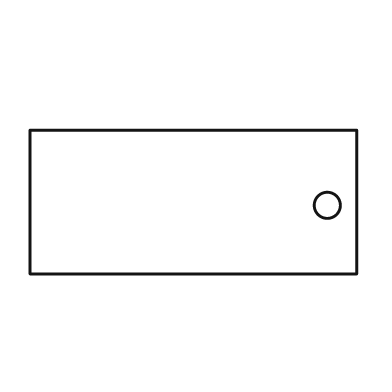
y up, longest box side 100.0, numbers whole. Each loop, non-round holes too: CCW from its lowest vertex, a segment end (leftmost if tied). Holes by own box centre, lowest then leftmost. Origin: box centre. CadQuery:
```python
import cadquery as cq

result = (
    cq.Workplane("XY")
    .moveTo(-50.0, -22.0)
    .lineTo(50.0, -22.0)
    .lineTo(50.0, 22.0)
    .lineTo(-50.0, 22.0)
    .close()
    .moveTo(41.0, -1.0)
    .circle(4.0)
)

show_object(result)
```